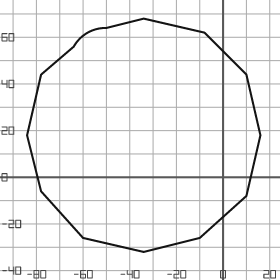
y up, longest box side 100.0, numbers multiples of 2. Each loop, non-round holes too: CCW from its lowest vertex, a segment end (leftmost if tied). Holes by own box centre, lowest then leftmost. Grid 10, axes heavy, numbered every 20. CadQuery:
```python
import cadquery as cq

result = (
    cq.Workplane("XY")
    .moveTo(-34.0, -32.0)
    .lineTo(-10.0, -26.0)
    .lineTo(10.0, -8.0)
    .lineTo(16.0, 18.0)
    .lineTo(10.0, 44.0)
    .lineTo(-8.0, 62.0)
    .lineTo(-34.0, 68.0)
    .lineTo(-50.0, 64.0)
    .threePointArc((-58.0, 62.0), (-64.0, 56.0))
    .lineTo(-78.0, 44.0)
    .lineTo(-84.0, 18.0)
    .lineTo(-78.0, -6.0)
    .lineTo(-60.0, -26.0)
    .close()
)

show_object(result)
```